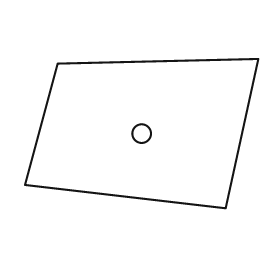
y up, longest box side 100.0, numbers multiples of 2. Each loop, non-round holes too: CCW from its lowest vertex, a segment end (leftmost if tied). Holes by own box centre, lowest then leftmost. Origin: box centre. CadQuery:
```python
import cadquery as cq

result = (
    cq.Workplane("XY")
    .moveTo(36.0, -32.0)
    .lineTo(50.0, 32.0)
    .lineTo(-36.0, 30.0)
    .lineTo(-50.0, -22.0)
    .close()
    .moveTo(0.0, 0.0)
    .circle(4.0)
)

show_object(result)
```